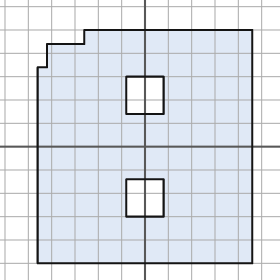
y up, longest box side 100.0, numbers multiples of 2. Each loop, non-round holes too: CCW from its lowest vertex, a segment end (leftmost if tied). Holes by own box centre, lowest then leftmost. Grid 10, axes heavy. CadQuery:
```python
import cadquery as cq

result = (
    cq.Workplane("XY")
    .moveTo(-46.0, -50.0)
    .lineTo(46.0, -50.0)
    .lineTo(46.0, 50.0)
    .lineTo(-26.0, 50.0)
    .lineTo(-26.0, 44.0)
    .lineTo(-42.0, 44.0)
    .lineTo(-42.0, 34.0)
    .lineTo(-46.0, 34.0)
    .close()
    .moveTo(-8.0, -30.0)
    .lineTo(8.0, -30.0)
    .lineTo(8.0, -14.0)
    .lineTo(-8.0, -14.0)
    .close()
    .moveTo(-8.0, 14.0)
    .lineTo(8.0, 14.0)
    .lineTo(8.0, 30.0)
    .lineTo(-8.0, 30.0)
    .close()
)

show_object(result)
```